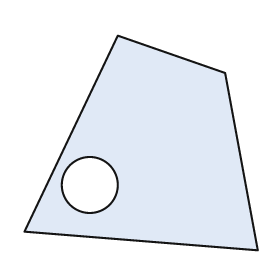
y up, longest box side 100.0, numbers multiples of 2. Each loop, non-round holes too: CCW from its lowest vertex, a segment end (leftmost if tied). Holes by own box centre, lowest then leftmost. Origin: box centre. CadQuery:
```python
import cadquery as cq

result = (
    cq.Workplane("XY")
    .moveTo(50.0, -46.0)
    .lineTo(36.0, 30.0)
    .lineTo(-10.0, 46.0)
    .lineTo(-50.0, -38.0)
    .close()
    .moveTo(-22.0, -18.0)
    .circle(12.0)
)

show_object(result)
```